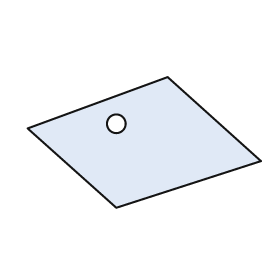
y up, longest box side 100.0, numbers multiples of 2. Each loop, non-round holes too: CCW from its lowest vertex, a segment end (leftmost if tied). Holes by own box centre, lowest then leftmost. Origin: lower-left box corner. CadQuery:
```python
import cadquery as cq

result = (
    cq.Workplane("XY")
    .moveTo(38.0, 0.0)
    .lineTo(100.0, 20.0)
    .lineTo(60.0, 56.0)
    .lineTo(0.0, 34.0)
    .close()
    .moveTo(38.0, 36.0)
    .circle(4.0)
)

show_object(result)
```